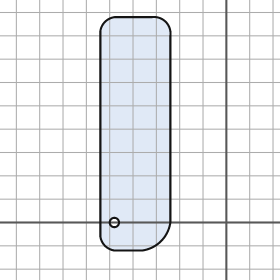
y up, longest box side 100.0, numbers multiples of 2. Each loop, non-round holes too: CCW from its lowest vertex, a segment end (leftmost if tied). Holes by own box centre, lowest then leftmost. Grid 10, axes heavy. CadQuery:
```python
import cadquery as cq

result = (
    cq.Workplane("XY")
    .moveTo(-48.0, -12.0)
    .lineTo(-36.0, -12.0)
    .threePointArc((-28.0, -8.0), (-24.0, 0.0))
    .lineTo(-24.0, 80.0)
    .threePointArc((-26.0, 86.0), (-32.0, 88.0))
    .lineTo(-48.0, 88.0)
    .threePointArc((-52.0, 86.0), (-54.0, 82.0))
    .lineTo(-54.0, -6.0)
    .threePointArc((-52.0, -10.0), (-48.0, -12.0))
    .close()
    .moveTo(-48.0, 0.0)
    .circle(2.0)
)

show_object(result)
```